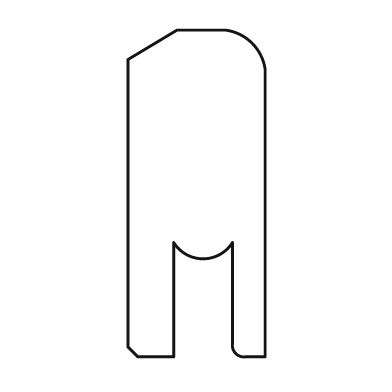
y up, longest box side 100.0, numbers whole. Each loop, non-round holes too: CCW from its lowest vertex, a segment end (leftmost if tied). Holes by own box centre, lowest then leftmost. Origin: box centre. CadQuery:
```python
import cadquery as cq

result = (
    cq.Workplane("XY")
    .moveTo(-18.0, -50.0)
    .lineTo(-7.0, -50.0)
    .lineTo(-7.0, -15.0)
    .threePointArc((2.0, -20.0), (11.0, -15.0))
    .lineTo(11.0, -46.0)
    .threePointArc((12.0, -49.0), (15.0, -50.0))
    .lineTo(21.0, -50.0)
    .lineTo(21.0, 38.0)
    .threePointArc((17.0, 46.0), (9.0, 50.0))
    .lineTo(-6.0, 50.0)
    .lineTo(-21.0, 41.0)
    .lineTo(-21.0, -47.0)
    .close()
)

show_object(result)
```